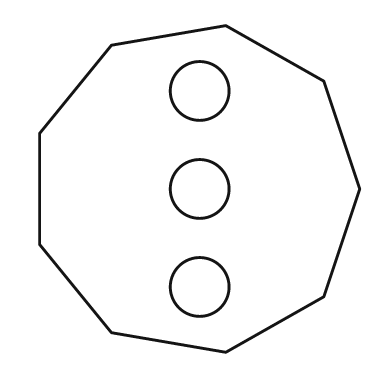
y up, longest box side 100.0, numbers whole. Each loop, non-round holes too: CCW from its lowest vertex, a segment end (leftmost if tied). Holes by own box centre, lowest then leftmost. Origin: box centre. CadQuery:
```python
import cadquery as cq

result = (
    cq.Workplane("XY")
    .moveTo(8.0, -50.0)
    .lineTo(38.0, -33.0)
    .lineTo(49.0, 0.0)
    .lineTo(38.0, 33.0)
    .lineTo(8.0, 50.0)
    .lineTo(-27.0, 44.0)
    .lineTo(-49.0, 17.0)
    .lineTo(-49.0, -17.0)
    .lineTo(-27.0, -44.0)
    .close()
    .moveTo(0.0, -30.0)
    .circle(9.0)
    .moveTo(0.0, 0.0)
    .circle(9.0)
    .moveTo(0.0, 30.0)
    .circle(9.0)
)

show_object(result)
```